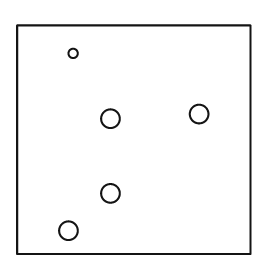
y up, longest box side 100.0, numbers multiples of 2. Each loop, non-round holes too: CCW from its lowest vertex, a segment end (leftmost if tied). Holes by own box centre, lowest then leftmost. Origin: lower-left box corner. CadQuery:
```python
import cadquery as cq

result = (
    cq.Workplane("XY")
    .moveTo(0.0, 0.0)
    .lineTo(100.0, 0.0)
    .lineTo(100.0, 98.0)
    .lineTo(0.0, 98.0)
    .close()
    .moveTo(22.0, 10.0)
    .circle(4.0)
    .moveTo(40.0, 26.0)
    .circle(4.0)
    .moveTo(40.0, 58.0)
    .circle(4.0)
    .moveTo(78.0, 60.0)
    .circle(4.0)
    .moveTo(24.0, 86.0)
    .circle(2.0)
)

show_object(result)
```